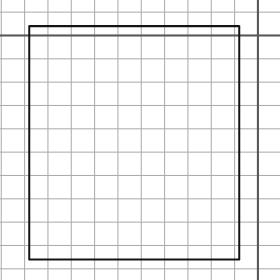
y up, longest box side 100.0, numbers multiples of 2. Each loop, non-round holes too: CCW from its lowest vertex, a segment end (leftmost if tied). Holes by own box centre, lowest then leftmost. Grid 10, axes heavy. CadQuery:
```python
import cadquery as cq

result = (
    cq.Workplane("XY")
    .moveTo(-98.0, -96.0)
    .lineTo(-8.0, -96.0)
    .lineTo(-8.0, 4.0)
    .lineTo(-98.0, 4.0)
    .close()
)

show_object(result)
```